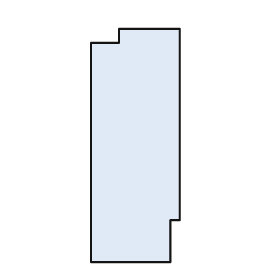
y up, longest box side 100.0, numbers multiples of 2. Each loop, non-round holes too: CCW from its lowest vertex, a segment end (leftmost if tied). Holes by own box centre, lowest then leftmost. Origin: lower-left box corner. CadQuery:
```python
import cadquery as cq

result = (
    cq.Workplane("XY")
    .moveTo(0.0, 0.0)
    .lineTo(34.0, 0.0)
    .lineTo(34.0, 18.0)
    .lineTo(38.0, 18.0)
    .lineTo(38.0, 100.0)
    .lineTo(12.0, 100.0)
    .lineTo(12.0, 94.0)
    .lineTo(0.0, 94.0)
    .close()
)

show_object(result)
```